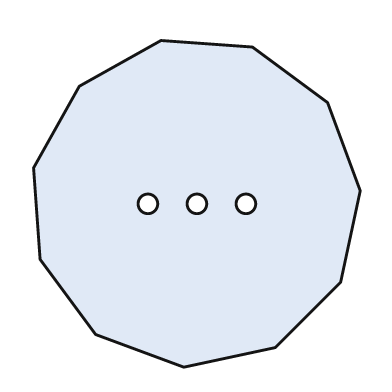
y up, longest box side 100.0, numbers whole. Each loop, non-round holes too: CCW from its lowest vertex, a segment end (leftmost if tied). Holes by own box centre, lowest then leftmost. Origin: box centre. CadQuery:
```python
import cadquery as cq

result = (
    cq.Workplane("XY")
    .moveTo(-4.0, -50.0)
    .lineTo(24.0, -44.0)
    .lineTo(44.0, -24.0)
    .lineTo(50.0, 4.0)
    .lineTo(40.0, 31.0)
    .lineTo(17.0, 48.0)
    .lineTo(-11.0, 50.0)
    .lineTo(-36.0, 36.0)
    .lineTo(-50.0, 11.0)
    .lineTo(-48.0, -17.0)
    .lineTo(-31.0, -40.0)
    .close()
    .moveTo(-15.0, 0.0)
    .circle(3.0)
    .moveTo(0.0, 0.0)
    .circle(3.0)
    .moveTo(15.0, 0.0)
    .circle(3.0)
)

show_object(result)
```